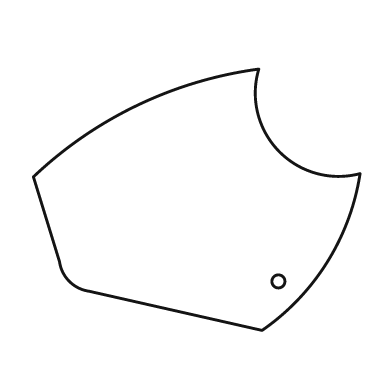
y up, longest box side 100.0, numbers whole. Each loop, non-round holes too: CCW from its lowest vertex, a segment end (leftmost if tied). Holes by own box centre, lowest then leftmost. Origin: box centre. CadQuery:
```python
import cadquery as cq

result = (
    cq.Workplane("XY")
    .moveTo(20.0, -40.0)
    .threePointArc((40.0, -19.0), (50.0, 8.0))
    .threePointArc((25.0, 15.0), (19.0, 40.0))
    .threePointArc((-18.0, 29.0), (-50.0, 7.0))
    .lineTo(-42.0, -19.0)
    .threePointArc((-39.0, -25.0), (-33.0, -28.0))
    .close()
    .moveTo(25.0, -25.0)
    .circle(2.0)
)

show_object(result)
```